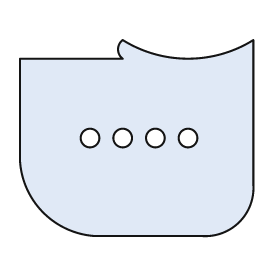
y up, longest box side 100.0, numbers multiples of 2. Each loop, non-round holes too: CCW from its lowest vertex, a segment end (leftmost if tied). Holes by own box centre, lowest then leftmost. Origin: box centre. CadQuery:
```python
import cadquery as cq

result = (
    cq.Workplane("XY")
    .moveTo(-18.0, -42.0)
    .lineTo(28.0, -42.0)
    .threePointArc((44.0, -36.0), (50.0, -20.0))
    .lineTo(50.0, 42.0)
    .threePointArc((22.0, 34.0), (-6.0, 42.0))
    .threePointArc((-8.0, 38.0), (-6.0, 34.0))
    .lineTo(-50.0, 34.0)
    .lineTo(-50.0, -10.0)
    .threePointArc((-40.0, -32.0), (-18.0, -42.0))
    .close()
    .moveTo(-20.0, 0.0)
    .circle(4.0)
    .moveTo(-6.0, 0.0)
    .circle(4.0)
    .moveTo(8.0, 0.0)
    .circle(4.0)
    .moveTo(22.0, 0.0)
    .circle(4.0)
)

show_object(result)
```